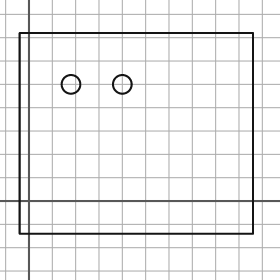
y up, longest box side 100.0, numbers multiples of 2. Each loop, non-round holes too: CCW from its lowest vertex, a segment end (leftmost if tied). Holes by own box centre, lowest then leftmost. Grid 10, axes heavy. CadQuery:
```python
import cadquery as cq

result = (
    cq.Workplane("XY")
    .moveTo(-4.0, -14.0)
    .lineTo(96.0, -14.0)
    .lineTo(96.0, 72.0)
    .lineTo(-4.0, 72.0)
    .close()
    .moveTo(18.0, 50.0)
    .circle(4.0)
    .moveTo(40.0, 50.0)
    .circle(4.0)
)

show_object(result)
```